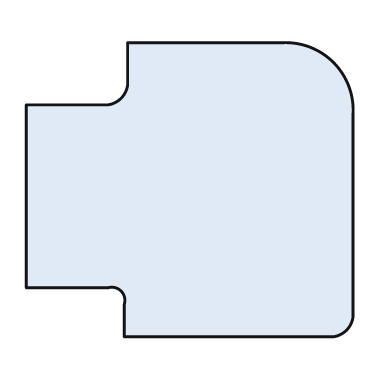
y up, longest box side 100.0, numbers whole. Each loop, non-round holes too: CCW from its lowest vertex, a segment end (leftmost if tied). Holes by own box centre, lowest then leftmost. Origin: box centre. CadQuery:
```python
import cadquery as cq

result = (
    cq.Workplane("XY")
    .moveTo(-20.0, -45.0)
    .lineTo(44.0, -45.0)
    .threePointArc((48.0, -43.0), (50.0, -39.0))
    .lineTo(50.0, 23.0)
    .threePointArc((44.0, 39.0), (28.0, 45.0))
    .lineTo(-19.0, 45.0)
    .lineTo(-19.0, 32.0)
    .threePointArc((-21.0, 28.0), (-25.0, 26.0))
    .lineTo(-50.0, 26.0)
    .lineTo(-50.0, -30.0)
    .lineTo(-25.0, -30.0)
    .threePointArc((-21.0, -31.0), (-20.0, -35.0))
    .close()
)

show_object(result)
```